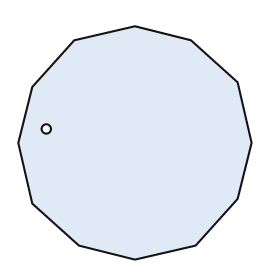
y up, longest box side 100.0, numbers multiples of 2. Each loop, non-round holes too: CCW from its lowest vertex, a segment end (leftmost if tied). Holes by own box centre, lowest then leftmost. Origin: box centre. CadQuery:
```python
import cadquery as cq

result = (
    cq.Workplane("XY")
    .moveTo(0.0, -50.0)
    .lineTo(26.0, -44.0)
    .lineTo(44.0, -24.0)
    .lineTo(50.0, 0.0)
    .lineTo(44.0, 26.0)
    .lineTo(24.0, 44.0)
    .lineTo(0.0, 50.0)
    .lineTo(-26.0, 44.0)
    .lineTo(-44.0, 24.0)
    .lineTo(-50.0, 0.0)
    .lineTo(-44.0, -26.0)
    .lineTo(-24.0, -44.0)
    .close()
    .moveTo(-38.0, 6.0)
    .circle(2.0)
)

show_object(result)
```